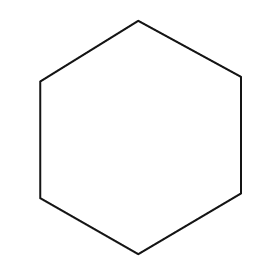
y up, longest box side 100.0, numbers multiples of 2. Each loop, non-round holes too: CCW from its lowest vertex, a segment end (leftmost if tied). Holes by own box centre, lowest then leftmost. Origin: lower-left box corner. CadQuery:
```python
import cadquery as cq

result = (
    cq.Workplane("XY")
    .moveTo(42.0, 0.0)
    .lineTo(86.0, 26.0)
    .lineTo(86.0, 76.0)
    .lineTo(42.0, 100.0)
    .lineTo(0.0, 74.0)
    .lineTo(0.0, 24.0)
    .close()
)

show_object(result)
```